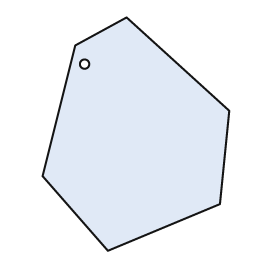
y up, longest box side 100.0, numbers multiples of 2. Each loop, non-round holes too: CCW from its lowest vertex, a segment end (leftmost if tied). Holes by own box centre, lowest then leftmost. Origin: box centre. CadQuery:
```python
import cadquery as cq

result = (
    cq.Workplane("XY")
    .moveTo(-12.0, -50.0)
    .lineTo(36.0, -30.0)
    .lineTo(40.0, 10.0)
    .lineTo(-4.0, 50.0)
    .lineTo(-26.0, 38.0)
    .lineTo(-40.0, -18.0)
    .close()
    .moveTo(-22.0, 30.0)
    .circle(2.0)
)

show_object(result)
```